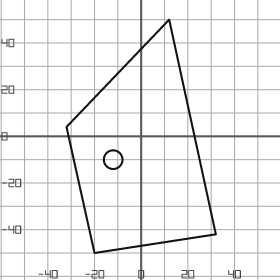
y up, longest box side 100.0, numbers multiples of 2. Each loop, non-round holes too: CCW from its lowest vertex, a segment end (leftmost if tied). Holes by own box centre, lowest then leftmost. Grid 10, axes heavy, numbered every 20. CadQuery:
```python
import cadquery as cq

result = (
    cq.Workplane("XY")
    .moveTo(-20.0, -50.0)
    .lineTo(32.0, -42.0)
    .lineTo(12.0, 50.0)
    .lineTo(-32.0, 4.0)
    .close()
    .moveTo(-12.0, -10.0)
    .circle(4.0)
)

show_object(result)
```